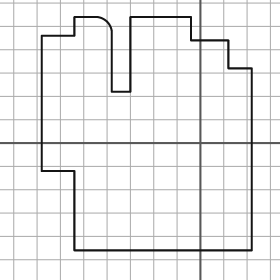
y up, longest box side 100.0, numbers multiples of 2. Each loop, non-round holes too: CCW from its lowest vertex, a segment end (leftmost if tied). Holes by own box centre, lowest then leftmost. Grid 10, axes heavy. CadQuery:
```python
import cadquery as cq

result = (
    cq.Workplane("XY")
    .moveTo(-54.0, -46.0)
    .lineTo(22.0, -46.0)
    .lineTo(22.0, 32.0)
    .lineTo(12.0, 32.0)
    .lineTo(12.0, 44.0)
    .lineTo(-4.0, 44.0)
    .lineTo(-4.0, 54.0)
    .lineTo(-30.0, 54.0)
    .lineTo(-30.0, 22.0)
    .lineTo(-38.0, 22.0)
    .lineTo(-38.0, 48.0)
    .threePointArc((-40.0, 52.0), (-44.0, 54.0))
    .lineTo(-54.0, 54.0)
    .lineTo(-54.0, 46.0)
    .lineTo(-68.0, 46.0)
    .lineTo(-68.0, -12.0)
    .lineTo(-54.0, -12.0)
    .close()
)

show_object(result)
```